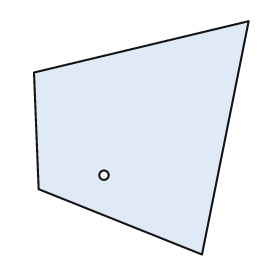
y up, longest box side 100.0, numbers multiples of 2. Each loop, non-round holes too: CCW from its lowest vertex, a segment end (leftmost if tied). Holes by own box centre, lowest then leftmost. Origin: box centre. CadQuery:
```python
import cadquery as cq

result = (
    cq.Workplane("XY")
    .moveTo(26.0, -50.0)
    .lineTo(46.0, 50.0)
    .lineTo(-46.0, 28.0)
    .lineTo(-44.0, -22.0)
    .close()
    .moveTo(-16.0, -16.0)
    .circle(2.0)
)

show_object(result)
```